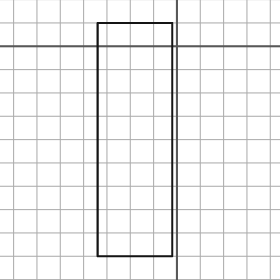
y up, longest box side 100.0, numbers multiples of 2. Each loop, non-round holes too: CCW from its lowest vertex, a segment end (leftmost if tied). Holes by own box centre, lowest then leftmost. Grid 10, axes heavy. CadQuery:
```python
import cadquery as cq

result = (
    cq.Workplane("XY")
    .moveTo(-34.0, -90.0)
    .lineTo(-2.0, -90.0)
    .lineTo(-2.0, 10.0)
    .lineTo(-34.0, 10.0)
    .close()
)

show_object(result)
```